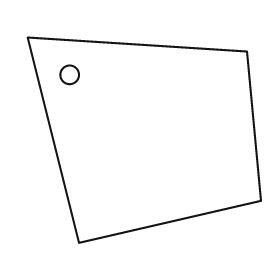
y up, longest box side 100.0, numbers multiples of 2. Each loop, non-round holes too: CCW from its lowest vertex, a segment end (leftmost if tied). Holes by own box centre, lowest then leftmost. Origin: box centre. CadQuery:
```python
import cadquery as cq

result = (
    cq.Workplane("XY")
    .moveTo(-28.0, -44.0)
    .lineTo(50.0, -26.0)
    .lineTo(44.0, 38.0)
    .lineTo(-50.0, 44.0)
    .close()
    .moveTo(-32.0, 28.0)
    .circle(4.0)
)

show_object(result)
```